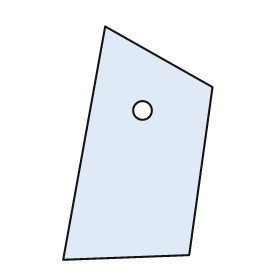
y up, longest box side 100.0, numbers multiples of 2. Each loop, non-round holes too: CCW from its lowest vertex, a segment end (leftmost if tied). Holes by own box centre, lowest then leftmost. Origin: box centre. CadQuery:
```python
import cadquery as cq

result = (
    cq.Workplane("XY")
    .moveTo(-32.0, -50.0)
    .lineTo(22.0, -48.0)
    .lineTo(32.0, 24.0)
    .lineTo(-14.0, 50.0)
    .close()
    .moveTo(2.0, 14.0)
    .circle(4.0)
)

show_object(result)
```